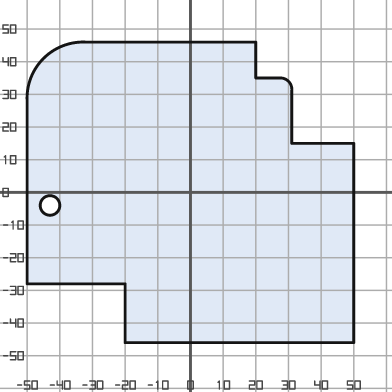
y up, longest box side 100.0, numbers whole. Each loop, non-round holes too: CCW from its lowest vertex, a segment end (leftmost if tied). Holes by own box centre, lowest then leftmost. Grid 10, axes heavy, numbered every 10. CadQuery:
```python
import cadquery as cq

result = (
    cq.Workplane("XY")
    .moveTo(-20.0, -46.0)
    .lineTo(50.0, -46.0)
    .lineTo(50.0, 15.0)
    .lineTo(31.0, 15.0)
    .lineTo(31.0, 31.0)
    .threePointArc((30.0, 34.0), (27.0, 35.0))
    .lineTo(20.0, 35.0)
    .lineTo(20.0, 46.0)
    .lineTo(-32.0, 46.0)
    .threePointArc((-45.0, 41.0), (-50.0, 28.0))
    .lineTo(-50.0, -28.0)
    .lineTo(-20.0, -28.0)
    .close()
    .moveTo(-43.0, -4.0)
    .circle(3.0)
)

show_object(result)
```